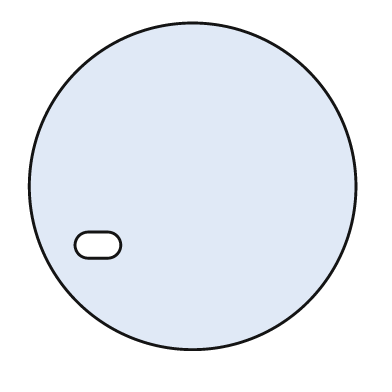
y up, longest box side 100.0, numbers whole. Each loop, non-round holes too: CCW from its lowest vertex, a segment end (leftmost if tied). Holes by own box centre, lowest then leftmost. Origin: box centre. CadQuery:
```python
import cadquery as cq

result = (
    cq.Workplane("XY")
    .moveTo(0.0, 0.0)
    .circle(50.0)
    .moveTo(-32.0, -22.0)
    .lineTo(-26.0, -22.0)
    .threePointArc((-22.0, -18.0), (-26.0, -14.0))
    .lineTo(-32.0, -14.0)
    .threePointArc((-36.0, -18.0), (-32.0, -22.0))
    .close()
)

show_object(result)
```